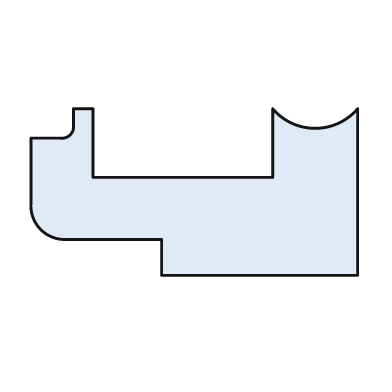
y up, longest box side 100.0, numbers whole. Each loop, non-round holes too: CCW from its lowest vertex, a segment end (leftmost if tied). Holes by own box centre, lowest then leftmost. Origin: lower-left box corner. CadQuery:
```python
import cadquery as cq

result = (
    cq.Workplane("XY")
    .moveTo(40.0, 0.0)
    .lineTo(100.0, 0.0)
    .lineTo(100.0, 51.0)
    .threePointArc((87.0, 45.0), (74.0, 51.0))
    .lineTo(74.0, 30.0)
    .lineTo(19.0, 30.0)
    .lineTo(19.0, 51.0)
    .lineTo(13.0, 51.0)
    .lineTo(13.0, 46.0)
    .threePointArc((12.0, 43.0), (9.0, 42.0))
    .lineTo(0.0, 42.0)
    .lineTo(0.0, 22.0)
    .threePointArc((3.0, 14.0), (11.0, 11.0))
    .lineTo(40.0, 11.0)
    .close()
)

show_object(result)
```